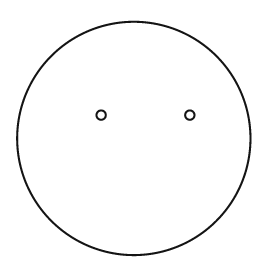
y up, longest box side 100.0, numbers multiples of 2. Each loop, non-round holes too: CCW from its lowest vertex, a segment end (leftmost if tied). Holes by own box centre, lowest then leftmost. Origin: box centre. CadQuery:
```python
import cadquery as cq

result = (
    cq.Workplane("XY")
    .moveTo(0.0, 0.0)
    .circle(50.0)
    .moveTo(-14.0, 10.0)
    .circle(2.0)
    .moveTo(24.0, 10.0)
    .circle(2.0)
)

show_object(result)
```